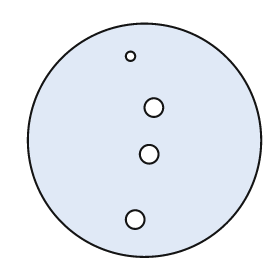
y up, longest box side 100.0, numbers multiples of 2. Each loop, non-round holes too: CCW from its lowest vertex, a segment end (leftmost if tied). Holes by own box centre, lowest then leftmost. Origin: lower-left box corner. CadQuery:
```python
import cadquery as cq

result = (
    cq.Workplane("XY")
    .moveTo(50.0, 50.0)
    .circle(50.0)
    .moveTo(46.0, 16.0)
    .circle(4.0)
    .moveTo(52.0, 44.0)
    .circle(4.0)
    .moveTo(54.0, 64.0)
    .circle(4.0)
    .moveTo(44.0, 86.0)
    .circle(2.0)
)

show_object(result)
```